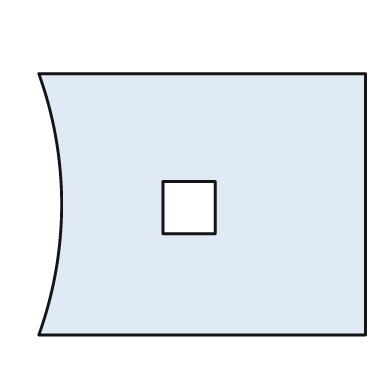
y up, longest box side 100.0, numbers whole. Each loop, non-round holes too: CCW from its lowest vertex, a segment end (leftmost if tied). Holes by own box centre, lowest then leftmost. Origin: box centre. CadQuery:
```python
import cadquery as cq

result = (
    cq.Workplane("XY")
    .moveTo(-50.0, -40.0)
    .lineTo(50.0, -40.0)
    .lineTo(50.0, 40.0)
    .lineTo(-50.0, 40.0)
    .threePointArc((-43.0, 0.0), (-50.0, -40.0))
    .close()
    .moveTo(-12.0, -9.0)
    .lineTo(4.0, -9.0)
    .lineTo(4.0, 7.0)
    .lineTo(-12.0, 7.0)
    .close()
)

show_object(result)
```